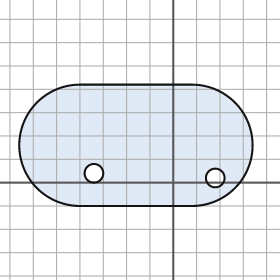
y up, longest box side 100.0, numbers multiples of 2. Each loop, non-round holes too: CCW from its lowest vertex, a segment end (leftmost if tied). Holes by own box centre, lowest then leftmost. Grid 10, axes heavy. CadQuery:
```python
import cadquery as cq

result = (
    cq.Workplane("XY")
    .moveTo(-40.0, -10.0)
    .lineTo(8.0, -10.0)
    .threePointArc((34.0, 16.0), (8.0, 42.0))
    .lineTo(-40.0, 42.0)
    .threePointArc((-66.0, 16.0), (-40.0, -10.0))
    .close()
    .moveTo(18.0, 2.0)
    .circle(4.0)
    .moveTo(-34.0, 4.0)
    .circle(4.0)
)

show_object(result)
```